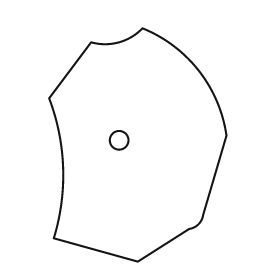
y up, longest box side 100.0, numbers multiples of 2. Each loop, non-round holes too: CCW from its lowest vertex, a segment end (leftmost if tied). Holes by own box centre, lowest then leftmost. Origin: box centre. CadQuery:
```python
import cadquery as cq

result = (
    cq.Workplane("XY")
    .moveTo(0.0, -50.0)
    .lineTo(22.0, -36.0)
    .threePointArc((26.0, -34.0), (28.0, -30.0))
    .lineTo(38.0, 4.0)
    .threePointArc((26.0, 32.0), (2.0, 50.0))
    .threePointArc((-8.0, 44.0), (-20.0, 44.0))
    .lineTo(-38.0, 20.0)
    .threePointArc((-32.0, -10.0), (-36.0, -40.0))
    .close()
    .moveTo(-8.0, 2.0)
    .circle(4.0)
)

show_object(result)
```